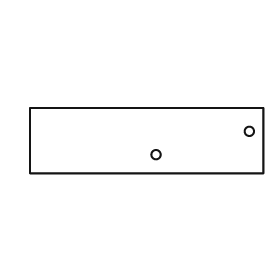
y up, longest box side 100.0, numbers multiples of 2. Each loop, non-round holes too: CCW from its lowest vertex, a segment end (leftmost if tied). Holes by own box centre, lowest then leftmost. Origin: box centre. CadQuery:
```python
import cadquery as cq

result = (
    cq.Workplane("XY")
    .moveTo(-50.0, -14.0)
    .lineTo(50.0, -14.0)
    .lineTo(50.0, 14.0)
    .lineTo(-50.0, 14.0)
    .close()
    .moveTo(4.0, -6.0)
    .circle(2.0)
    .moveTo(44.0, 4.0)
    .circle(2.0)
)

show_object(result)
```